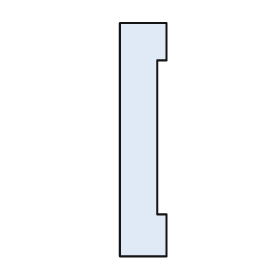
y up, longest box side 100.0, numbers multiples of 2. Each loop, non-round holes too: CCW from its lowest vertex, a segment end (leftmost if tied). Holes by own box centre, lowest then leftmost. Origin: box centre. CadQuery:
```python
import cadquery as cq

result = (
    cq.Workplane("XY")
    .moveTo(-10.0, -50.0)
    .lineTo(10.0, -50.0)
    .lineTo(10.0, -32.0)
    .lineTo(6.0, -32.0)
    .lineTo(6.0, 34.0)
    .lineTo(10.0, 34.0)
    .lineTo(10.0, 50.0)
    .lineTo(-10.0, 50.0)
    .close()
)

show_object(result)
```